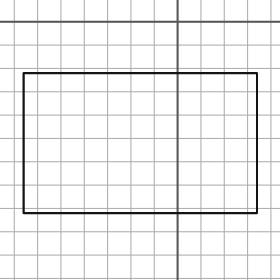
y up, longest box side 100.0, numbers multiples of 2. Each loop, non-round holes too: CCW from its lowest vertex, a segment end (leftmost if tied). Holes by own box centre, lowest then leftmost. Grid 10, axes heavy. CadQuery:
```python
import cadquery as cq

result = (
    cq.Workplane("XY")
    .moveTo(-66.0, -82.0)
    .lineTo(34.0, -82.0)
    .lineTo(34.0, -22.0)
    .lineTo(-66.0, -22.0)
    .close()
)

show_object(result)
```